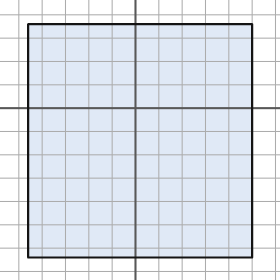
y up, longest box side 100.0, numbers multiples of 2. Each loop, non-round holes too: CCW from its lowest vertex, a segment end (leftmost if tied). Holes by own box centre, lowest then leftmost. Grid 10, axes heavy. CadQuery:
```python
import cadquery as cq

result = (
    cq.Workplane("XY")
    .moveTo(-46.0, -64.0)
    .lineTo(50.0, -64.0)
    .lineTo(50.0, 36.0)
    .lineTo(-46.0, 36.0)
    .close()
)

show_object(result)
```